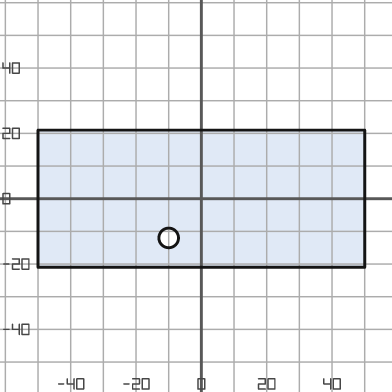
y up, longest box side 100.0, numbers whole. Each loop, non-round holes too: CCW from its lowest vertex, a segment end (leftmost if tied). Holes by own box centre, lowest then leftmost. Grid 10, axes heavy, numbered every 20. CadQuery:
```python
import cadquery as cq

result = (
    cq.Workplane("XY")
    .moveTo(-50.0, -21.0)
    .lineTo(50.0, -21.0)
    .lineTo(50.0, 21.0)
    .lineTo(-50.0, 21.0)
    .close()
    .moveTo(-10.0, -12.0)
    .circle(3.0)
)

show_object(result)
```